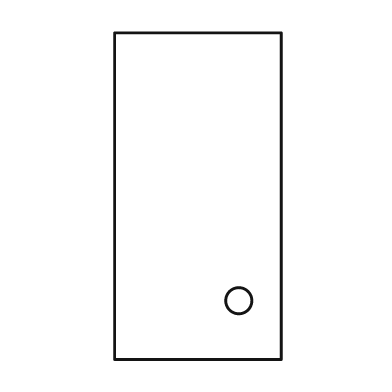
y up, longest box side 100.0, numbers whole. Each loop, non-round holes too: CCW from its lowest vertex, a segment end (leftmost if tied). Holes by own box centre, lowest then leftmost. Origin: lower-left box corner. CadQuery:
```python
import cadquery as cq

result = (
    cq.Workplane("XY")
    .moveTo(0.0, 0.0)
    .lineTo(51.0, 0.0)
    .lineTo(51.0, 100.0)
    .lineTo(0.0, 100.0)
    .close()
    .moveTo(38.0, 18.0)
    .circle(4.0)
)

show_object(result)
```